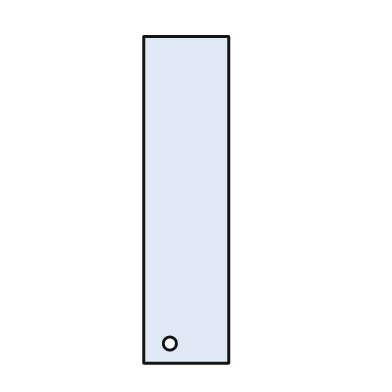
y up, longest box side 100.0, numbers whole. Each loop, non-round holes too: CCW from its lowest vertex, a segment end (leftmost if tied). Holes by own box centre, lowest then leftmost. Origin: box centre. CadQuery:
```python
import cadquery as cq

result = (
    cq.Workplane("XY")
    .moveTo(-13.0, -50.0)
    .lineTo(13.0, -50.0)
    .lineTo(13.0, 50.0)
    .lineTo(-13.0, 50.0)
    .close()
    .moveTo(-5.0, -44.0)
    .circle(2.0)
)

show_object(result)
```